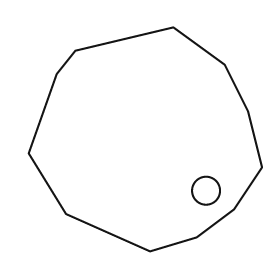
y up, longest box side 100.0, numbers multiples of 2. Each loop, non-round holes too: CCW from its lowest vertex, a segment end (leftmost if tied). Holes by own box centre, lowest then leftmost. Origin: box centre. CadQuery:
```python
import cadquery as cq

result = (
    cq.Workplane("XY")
    .moveTo(2.0, -48.0)
    .lineTo(22.0, -42.0)
    .lineTo(38.0, -30.0)
    .lineTo(50.0, -12.0)
    .lineTo(44.0, 12.0)
    .lineTo(34.0, 32.0)
    .lineTo(12.0, 48.0)
    .lineTo(-30.0, 38.0)
    .lineTo(-38.0, 28.0)
    .lineTo(-50.0, -6.0)
    .lineTo(-34.0, -32.0)
    .close()
    .moveTo(26.0, -22.0)
    .circle(6.0)
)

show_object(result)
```